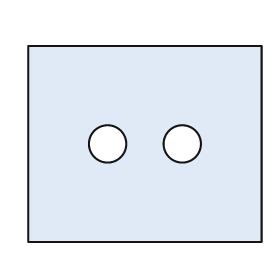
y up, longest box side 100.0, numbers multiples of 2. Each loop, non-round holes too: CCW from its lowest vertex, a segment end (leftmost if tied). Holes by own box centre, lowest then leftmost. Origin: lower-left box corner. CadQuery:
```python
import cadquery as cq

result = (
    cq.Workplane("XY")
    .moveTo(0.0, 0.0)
    .lineTo(100.0, 0.0)
    .lineTo(100.0, 84.0)
    .lineTo(0.0, 84.0)
    .close()
    .moveTo(34.0, 42.0)
    .circle(8.0)
    .moveTo(66.0, 42.0)
    .circle(8.0)
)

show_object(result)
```